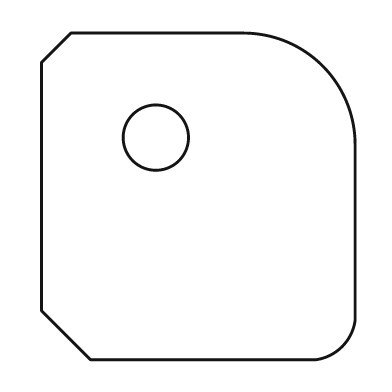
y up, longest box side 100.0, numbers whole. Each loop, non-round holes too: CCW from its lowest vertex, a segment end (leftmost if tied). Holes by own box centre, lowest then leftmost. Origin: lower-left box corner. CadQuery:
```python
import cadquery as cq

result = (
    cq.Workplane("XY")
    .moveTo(15.0, 0.0)
    .lineTo(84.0, 0.0)
    .threePointArc((92.0, 4.0), (96.0, 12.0))
    .lineTo(96.0, 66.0)
    .threePointArc((86.0, 90.0), (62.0, 100.0))
    .lineTo(9.0, 100.0)
    .lineTo(0.0, 91.0)
    .lineTo(0.0, 15.0)
    .close()
    .moveTo(35.0, 68.0)
    .circle(10.0)
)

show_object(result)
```